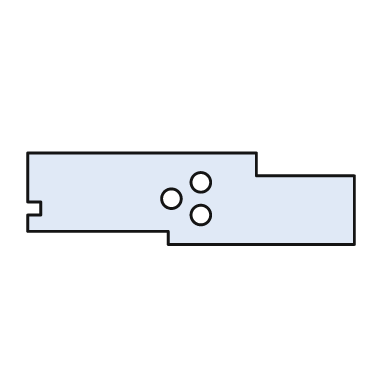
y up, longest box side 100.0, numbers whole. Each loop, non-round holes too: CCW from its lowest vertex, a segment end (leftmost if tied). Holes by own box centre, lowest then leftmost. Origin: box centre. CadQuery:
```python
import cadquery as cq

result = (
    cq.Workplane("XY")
    .moveTo(-7.0, -14.0)
    .lineTo(50.0, -14.0)
    .lineTo(50.0, 7.0)
    .lineTo(20.0, 7.0)
    .lineTo(20.0, 14.0)
    .lineTo(-50.0, 14.0)
    .lineTo(-50.0, -1.0)
    .lineTo(-46.0, -1.0)
    .lineTo(-46.0, -5.0)
    .lineTo(-50.0, -5.0)
    .lineTo(-50.0, -10.0)
    .lineTo(-7.0, -10.0)
    .close()
    .moveTo(3.0, -5.0)
    .circle(3.0)
    .moveTo(-6.0, 0.0)
    .circle(3.0)
    .moveTo(3.0, 5.0)
    .circle(3.0)
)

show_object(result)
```